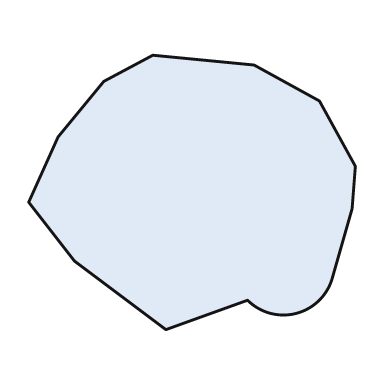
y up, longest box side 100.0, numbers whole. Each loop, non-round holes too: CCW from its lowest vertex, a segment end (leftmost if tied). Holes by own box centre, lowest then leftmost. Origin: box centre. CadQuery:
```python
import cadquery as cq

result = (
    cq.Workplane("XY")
    .moveTo(-8.0, -42.0)
    .lineTo(17.0, -33.0)
    .threePointArc((32.0, -37.0), (43.0, -26.0))
    .lineTo(49.0, -5.0)
    .lineTo(50.0, 8.0)
    .lineTo(39.0, 28.0)
    .lineTo(19.0, 39.0)
    .lineTo(-12.0, 42.0)
    .lineTo(-27.0, 34.0)
    .lineTo(-41.0, 17.0)
    .lineTo(-50.0, -3.0)
    .lineTo(-36.0, -21.0)
    .close()
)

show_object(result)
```